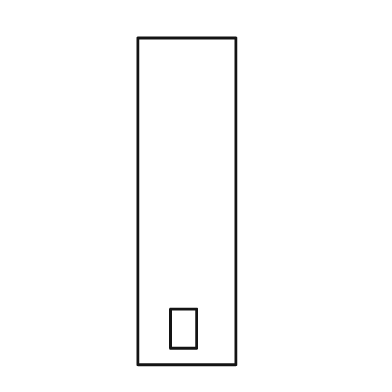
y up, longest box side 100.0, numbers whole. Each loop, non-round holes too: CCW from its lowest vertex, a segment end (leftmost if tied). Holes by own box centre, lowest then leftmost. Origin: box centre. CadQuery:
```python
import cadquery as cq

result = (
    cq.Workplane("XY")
    .moveTo(-15.0, -50.0)
    .lineTo(15.0, -50.0)
    .lineTo(15.0, 50.0)
    .lineTo(-15.0, 50.0)
    .close()
    .moveTo(-5.0, -45.0)
    .lineTo(3.0, -45.0)
    .lineTo(3.0, -33.0)
    .lineTo(-5.0, -33.0)
    .close()
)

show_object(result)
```